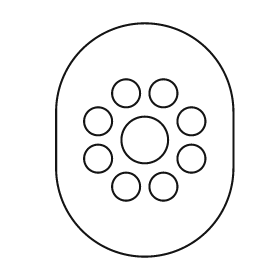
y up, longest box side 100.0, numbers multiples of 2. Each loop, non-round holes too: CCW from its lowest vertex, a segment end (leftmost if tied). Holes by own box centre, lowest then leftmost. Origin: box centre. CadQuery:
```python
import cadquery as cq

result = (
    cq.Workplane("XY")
    .moveTo(-38.0, -12.0)
    .threePointArc((0.0, -50.0), (38.0, -12.0))
    .lineTo(38.0, 12.0)
    .threePointArc((0.0, 50.0), (-38.0, 12.0))
    .close()
    .moveTo(-8.0, -20.0)
    .circle(6.0)
    .moveTo(8.0, -20.0)
    .circle(6.0)
    .moveTo(-20.0, -8.0)
    .circle(6.0)
    .moveTo(20.0, -8.0)
    .circle(6.0)
    .moveTo(0.0, 0.0)
    .circle(10.0)
    .moveTo(-20.0, 8.0)
    .circle(6.0)
    .moveTo(20.0, 8.0)
    .circle(6.0)
    .moveTo(-8.0, 20.0)
    .circle(6.0)
    .moveTo(8.0, 20.0)
    .circle(6.0)
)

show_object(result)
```